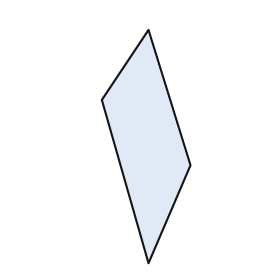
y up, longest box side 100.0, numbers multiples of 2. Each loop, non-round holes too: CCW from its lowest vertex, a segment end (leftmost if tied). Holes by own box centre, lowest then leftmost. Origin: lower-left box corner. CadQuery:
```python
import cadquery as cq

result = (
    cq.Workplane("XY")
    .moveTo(20.0, 0.0)
    .lineTo(38.0, 42.0)
    .lineTo(20.0, 100.0)
    .lineTo(0.0, 70.0)
    .close()
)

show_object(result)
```